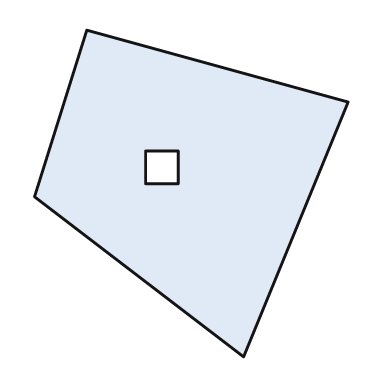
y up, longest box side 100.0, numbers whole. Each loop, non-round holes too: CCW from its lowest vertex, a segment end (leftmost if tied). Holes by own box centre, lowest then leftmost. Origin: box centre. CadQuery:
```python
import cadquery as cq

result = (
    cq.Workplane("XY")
    .moveTo(16.0, -50.0)
    .lineTo(48.0, 28.0)
    .lineTo(-32.0, 50.0)
    .lineTo(-48.0, -1.0)
    .close()
    .moveTo(-14.0, 3.0)
    .lineTo(-4.0, 3.0)
    .lineTo(-4.0, 13.0)
    .lineTo(-14.0, 13.0)
    .close()
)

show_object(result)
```